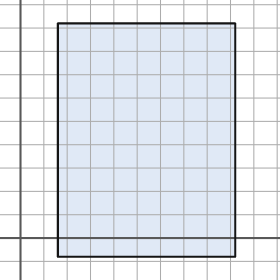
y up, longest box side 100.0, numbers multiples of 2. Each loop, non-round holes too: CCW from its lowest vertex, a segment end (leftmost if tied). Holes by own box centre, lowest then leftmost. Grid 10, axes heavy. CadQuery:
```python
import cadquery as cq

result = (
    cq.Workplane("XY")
    .moveTo(16.0, -8.0)
    .lineTo(92.0, -8.0)
    .lineTo(92.0, 92.0)
    .lineTo(16.0, 92.0)
    .close()
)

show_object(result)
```